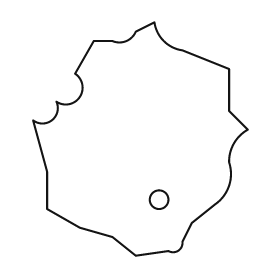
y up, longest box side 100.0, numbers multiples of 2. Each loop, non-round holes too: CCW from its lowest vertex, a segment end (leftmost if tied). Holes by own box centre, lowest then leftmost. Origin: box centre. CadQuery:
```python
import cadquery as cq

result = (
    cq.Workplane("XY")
    .moveTo(-2.0, -50.0)
    .lineTo(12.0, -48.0)
    .threePointArc((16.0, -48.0), (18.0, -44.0))
    .lineTo(22.0, -36.0)
    .lineTo(32.0, -28.0)
    .threePointArc((38.0, -20.0), (38.0, -10.0))
    .threePointArc((40.0, -2.0), (46.0, 4.0))
    .lineTo(38.0, 12.0)
    .lineTo(38.0, 30.0)
    .lineTo(18.0, 38.0)
    .threePointArc((10.0, 42.0), (6.0, 50.0))
    .lineTo(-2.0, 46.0)
    .threePointArc((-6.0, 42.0), (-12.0, 42.0))
    .lineTo(-20.0, 42.0)
    .lineTo(-28.0, 28.0)
    .threePointArc((-26.0, 18.0), (-36.0, 16.0))
    .threePointArc((-38.0, 8.0), (-46.0, 8.0))
    .lineTo(-40.0, -14.0)
    .lineTo(-40.0, -30.0)
    .lineTo(-26.0, -38.0)
    .lineTo(-12.0, -42.0)
    .close()
    .moveTo(8.0, -26.0)
    .circle(4.0)
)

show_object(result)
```